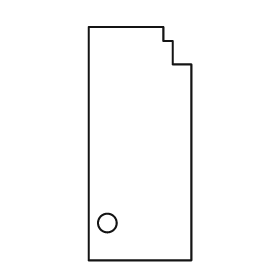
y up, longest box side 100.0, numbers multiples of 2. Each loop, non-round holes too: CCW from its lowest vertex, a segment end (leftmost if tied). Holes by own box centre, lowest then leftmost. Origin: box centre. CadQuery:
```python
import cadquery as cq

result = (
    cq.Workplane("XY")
    .moveTo(-22.0, -50.0)
    .lineTo(22.0, -50.0)
    .lineTo(22.0, 34.0)
    .lineTo(14.0, 34.0)
    .lineTo(14.0, 44.0)
    .lineTo(10.0, 44.0)
    .lineTo(10.0, 50.0)
    .lineTo(-22.0, 50.0)
    .close()
    .moveTo(-14.0, -34.0)
    .circle(4.0)
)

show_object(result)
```